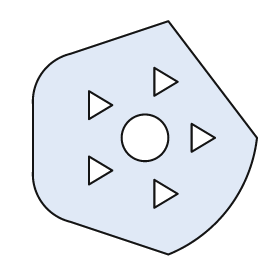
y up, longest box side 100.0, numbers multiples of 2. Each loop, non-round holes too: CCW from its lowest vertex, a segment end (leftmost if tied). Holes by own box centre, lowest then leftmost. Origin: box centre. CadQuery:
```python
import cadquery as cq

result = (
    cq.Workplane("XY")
    .moveTo(10.0, -50.0)
    .threePointArc((36.0, -30.0), (48.0, 0.0))
    .lineTo(10.0, 50.0)
    .lineTo(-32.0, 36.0)
    .threePointArc((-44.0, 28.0), (-48.0, 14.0))
    .lineTo(-48.0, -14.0)
    .threePointArc((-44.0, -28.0), (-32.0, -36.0))
    .close()
    .moveTo(4.0, -30.0)
    .lineTo(14.0, -24.0)
    .lineTo(4.0, -18.0)
    .close()
    .moveTo(-24.0, -20.0)
    .lineTo(-14.0, -14.0)
    .lineTo(-24.0, -8.0)
    .close()
    .moveTo(0.0, 0.0)
    .circle(10.0)
    .moveTo(20.0, -6.0)
    .lineTo(30.0, 0.0)
    .lineTo(20.0, 6.0)
    .close()
    .moveTo(-24.0, 8.0)
    .lineTo(-14.0, 14.0)
    .lineTo(-24.0, 20.0)
    .close()
    .moveTo(4.0, 18.0)
    .lineTo(14.0, 24.0)
    .lineTo(4.0, 30.0)
    .close()
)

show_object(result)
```